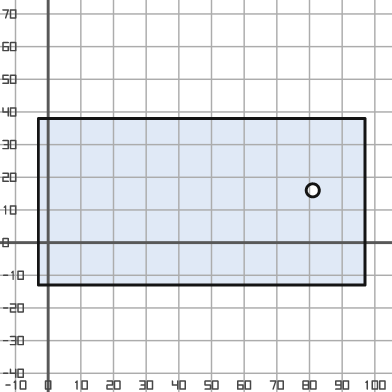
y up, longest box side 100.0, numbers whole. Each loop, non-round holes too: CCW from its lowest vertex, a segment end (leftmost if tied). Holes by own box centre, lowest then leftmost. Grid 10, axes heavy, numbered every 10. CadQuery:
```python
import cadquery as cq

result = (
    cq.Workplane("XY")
    .moveTo(-3.0, -13.0)
    .lineTo(97.0, -13.0)
    .lineTo(97.0, 38.0)
    .lineTo(-3.0, 38.0)
    .close()
    .moveTo(81.0, 16.0)
    .circle(2.0)
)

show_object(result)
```